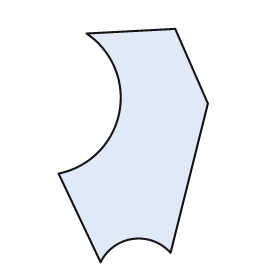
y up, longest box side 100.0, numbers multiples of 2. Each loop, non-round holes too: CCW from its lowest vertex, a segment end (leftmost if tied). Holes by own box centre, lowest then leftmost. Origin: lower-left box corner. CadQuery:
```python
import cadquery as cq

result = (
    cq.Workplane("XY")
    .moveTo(18.0, 0.0)
    .threePointArc((32.0, 10.0), (48.0, 4.0))
    .lineTo(64.0, 68.0)
    .lineTo(50.0, 100.0)
    .lineTo(12.0, 98.0)
    .threePointArc((26.0, 64.0), (0.0, 38.0))
    .close()
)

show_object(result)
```